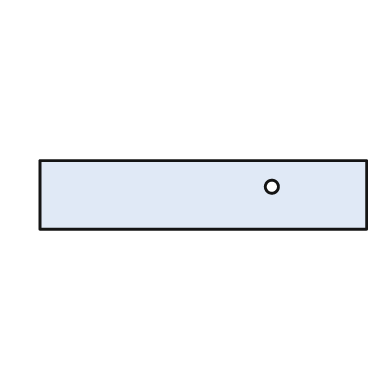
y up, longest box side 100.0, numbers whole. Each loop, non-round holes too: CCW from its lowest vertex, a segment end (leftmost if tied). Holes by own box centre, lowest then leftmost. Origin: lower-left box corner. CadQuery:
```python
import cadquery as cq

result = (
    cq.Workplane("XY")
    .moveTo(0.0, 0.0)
    .lineTo(100.0, 0.0)
    .lineTo(100.0, 21.0)
    .lineTo(0.0, 21.0)
    .close()
    .moveTo(71.0, 13.0)
    .circle(2.0)
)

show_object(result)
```